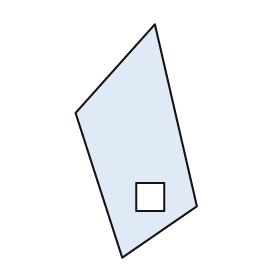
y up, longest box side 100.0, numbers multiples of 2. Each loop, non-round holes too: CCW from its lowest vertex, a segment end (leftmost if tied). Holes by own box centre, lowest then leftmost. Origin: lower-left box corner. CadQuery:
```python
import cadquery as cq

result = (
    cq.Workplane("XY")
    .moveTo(20.0, 0.0)
    .lineTo(52.0, 22.0)
    .lineTo(34.0, 100.0)
    .lineTo(0.0, 62.0)
    .close()
    .moveTo(26.0, 20.0)
    .lineTo(38.0, 20.0)
    .lineTo(38.0, 32.0)
    .lineTo(26.0, 32.0)
    .close()
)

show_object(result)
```